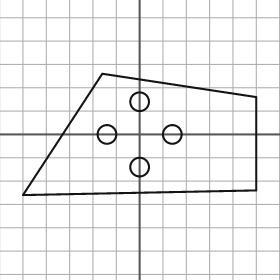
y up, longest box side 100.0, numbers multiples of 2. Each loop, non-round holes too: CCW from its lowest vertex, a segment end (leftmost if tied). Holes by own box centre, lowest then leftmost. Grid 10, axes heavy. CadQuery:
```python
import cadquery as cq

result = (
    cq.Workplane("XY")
    .moveTo(-50.0, -26.0)
    .lineTo(50.0, -24.0)
    .lineTo(50.0, 16.0)
    .lineTo(-16.0, 26.0)
    .close()
    .moveTo(0.0, -14.0)
    .circle(4.0)
    .moveTo(-14.0, 0.0)
    .circle(4.0)
    .moveTo(14.0, 0.0)
    .circle(4.0)
    .moveTo(0.0, 14.0)
    .circle(4.0)
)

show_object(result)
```